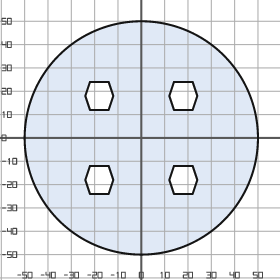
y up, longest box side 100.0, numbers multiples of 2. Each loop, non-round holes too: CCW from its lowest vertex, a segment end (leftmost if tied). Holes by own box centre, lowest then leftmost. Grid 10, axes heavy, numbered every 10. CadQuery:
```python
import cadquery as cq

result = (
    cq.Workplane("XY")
    .moveTo(0.0, 0.0)
    .circle(50.0)
    .moveTo(-22.0, -24.0)
    .lineTo(-14.0, -24.0)
    .lineTo(-12.0, -18.0)
    .lineTo(-14.0, -12.0)
    .lineTo(-22.0, -12.0)
    .lineTo(-24.0, -18.0)
    .close()
    .moveTo(14.0, -24.0)
    .lineTo(22.0, -24.0)
    .lineTo(24.0, -18.0)
    .lineTo(22.0, -12.0)
    .lineTo(14.0, -12.0)
    .lineTo(12.0, -18.0)
    .close()
    .moveTo(-22.0, 12.0)
    .lineTo(-14.0, 12.0)
    .lineTo(-12.0, 18.0)
    .lineTo(-14.0, 24.0)
    .lineTo(-22.0, 24.0)
    .lineTo(-24.0, 18.0)
    .close()
    .moveTo(14.0, 12.0)
    .lineTo(22.0, 12.0)
    .lineTo(24.0, 18.0)
    .lineTo(22.0, 24.0)
    .lineTo(14.0, 24.0)
    .lineTo(12.0, 18.0)
    .close()
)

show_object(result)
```